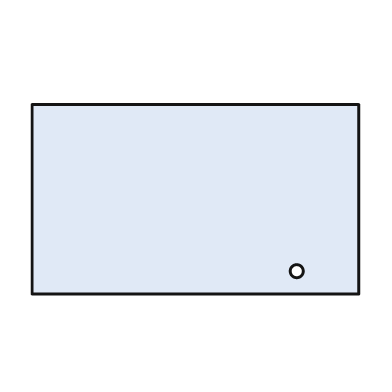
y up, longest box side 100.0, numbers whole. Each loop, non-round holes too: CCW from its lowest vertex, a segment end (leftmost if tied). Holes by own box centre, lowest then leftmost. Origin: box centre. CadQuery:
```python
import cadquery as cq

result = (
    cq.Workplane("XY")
    .moveTo(-50.0, -29.0)
    .lineTo(50.0, -29.0)
    .lineTo(50.0, 29.0)
    .lineTo(-50.0, 29.0)
    .close()
    .moveTo(31.0, -22.0)
    .circle(2.0)
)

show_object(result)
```